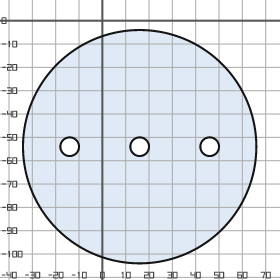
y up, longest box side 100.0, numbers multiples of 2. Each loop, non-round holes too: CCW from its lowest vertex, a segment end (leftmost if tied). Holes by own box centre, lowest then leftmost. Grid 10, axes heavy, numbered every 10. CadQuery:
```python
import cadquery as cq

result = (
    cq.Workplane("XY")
    .moveTo(16.0, -54.0)
    .circle(50.0)
    .moveTo(-14.0, -54.0)
    .circle(4.0)
    .moveTo(16.0, -54.0)
    .circle(4.0)
    .moveTo(46.0, -54.0)
    .circle(4.0)
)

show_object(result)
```